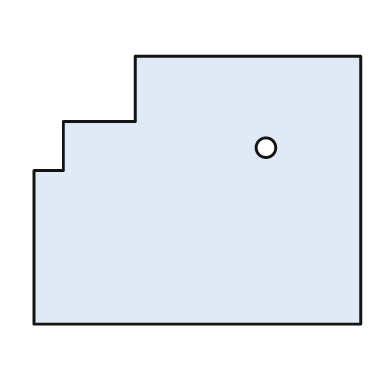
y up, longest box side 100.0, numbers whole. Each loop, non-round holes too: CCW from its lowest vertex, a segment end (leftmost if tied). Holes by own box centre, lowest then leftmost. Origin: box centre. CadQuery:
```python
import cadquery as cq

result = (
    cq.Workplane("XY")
    .moveTo(-50.0, -41.0)
    .lineTo(50.0, -41.0)
    .lineTo(50.0, 41.0)
    .lineTo(-19.0, 41.0)
    .lineTo(-19.0, 21.0)
    .lineTo(-41.0, 21.0)
    .lineTo(-41.0, 6.0)
    .lineTo(-50.0, 6.0)
    .close()
    .moveTo(21.0, 13.0)
    .circle(3.0)
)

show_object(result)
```